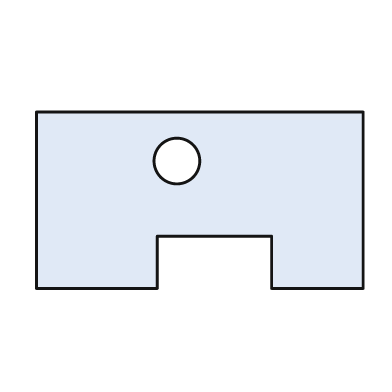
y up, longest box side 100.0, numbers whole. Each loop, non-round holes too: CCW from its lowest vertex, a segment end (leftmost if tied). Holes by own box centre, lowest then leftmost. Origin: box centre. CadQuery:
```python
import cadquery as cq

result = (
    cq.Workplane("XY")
    .moveTo(-50.0, -27.0)
    .lineTo(-13.0, -27.0)
    .lineTo(-13.0, -11.0)
    .lineTo(22.0, -11.0)
    .lineTo(22.0, -27.0)
    .lineTo(50.0, -27.0)
    .lineTo(50.0, 27.0)
    .lineTo(-50.0, 27.0)
    .close()
    .moveTo(-7.0, 12.0)
    .circle(7.0)
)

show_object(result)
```